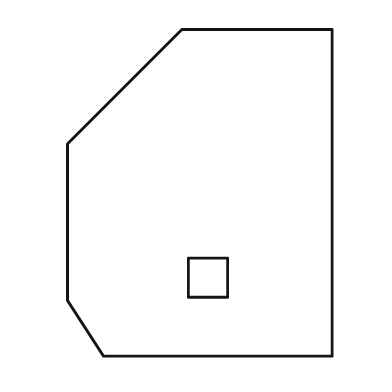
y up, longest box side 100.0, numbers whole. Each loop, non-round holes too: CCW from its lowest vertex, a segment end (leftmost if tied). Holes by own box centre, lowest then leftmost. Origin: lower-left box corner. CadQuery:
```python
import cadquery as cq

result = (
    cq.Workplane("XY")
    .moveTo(11.0, 0.0)
    .lineTo(81.0, 0.0)
    .lineTo(81.0, 100.0)
    .lineTo(35.0, 100.0)
    .lineTo(0.0, 65.0)
    .lineTo(0.0, 17.0)
    .close()
    .moveTo(37.0, 18.0)
    .lineTo(49.0, 18.0)
    .lineTo(49.0, 30.0)
    .lineTo(37.0, 30.0)
    .close()
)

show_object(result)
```